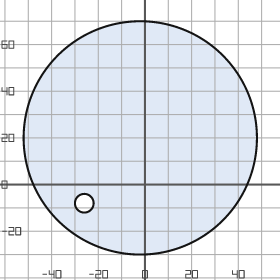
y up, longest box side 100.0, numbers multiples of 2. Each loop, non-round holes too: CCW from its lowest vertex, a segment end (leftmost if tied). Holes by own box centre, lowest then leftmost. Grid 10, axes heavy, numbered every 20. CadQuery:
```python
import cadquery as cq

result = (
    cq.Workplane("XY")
    .moveTo(-2.0, 20.0)
    .circle(50.0)
    .moveTo(-26.0, -8.0)
    .circle(4.0)
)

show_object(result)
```